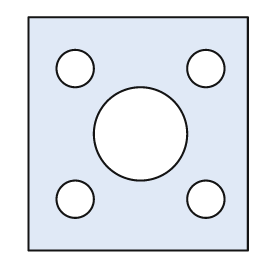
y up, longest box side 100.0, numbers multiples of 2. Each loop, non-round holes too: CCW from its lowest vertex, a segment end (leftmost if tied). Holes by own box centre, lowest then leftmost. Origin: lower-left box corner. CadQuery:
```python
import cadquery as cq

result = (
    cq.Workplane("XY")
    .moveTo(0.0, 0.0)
    .lineTo(94.0, 0.0)
    .lineTo(94.0, 100.0)
    .lineTo(0.0, 100.0)
    .close()
    .moveTo(20.0, 22.0)
    .circle(8.0)
    .moveTo(76.0, 22.0)
    .circle(8.0)
    .moveTo(48.0, 50.0)
    .circle(20.0)
    .moveTo(20.0, 78.0)
    .circle(8.0)
    .moveTo(76.0, 78.0)
    .circle(8.0)
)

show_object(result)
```